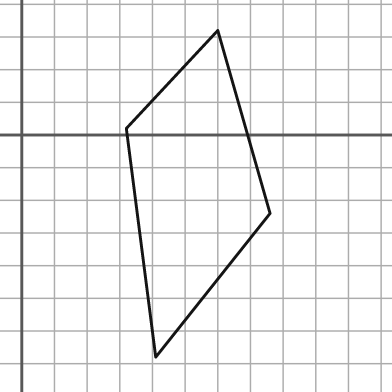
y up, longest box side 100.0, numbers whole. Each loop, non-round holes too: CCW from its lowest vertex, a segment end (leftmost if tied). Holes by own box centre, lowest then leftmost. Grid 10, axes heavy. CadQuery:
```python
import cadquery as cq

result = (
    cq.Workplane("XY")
    .moveTo(41.0, -68.0)
    .lineTo(76.0, -24.0)
    .lineTo(60.0, 32.0)
    .lineTo(32.0, 2.0)
    .close()
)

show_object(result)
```